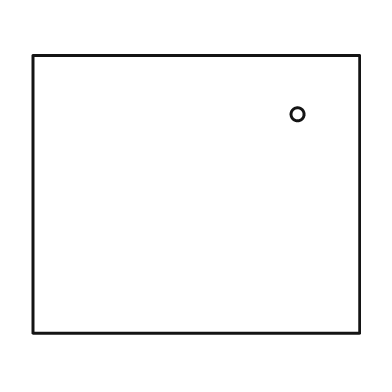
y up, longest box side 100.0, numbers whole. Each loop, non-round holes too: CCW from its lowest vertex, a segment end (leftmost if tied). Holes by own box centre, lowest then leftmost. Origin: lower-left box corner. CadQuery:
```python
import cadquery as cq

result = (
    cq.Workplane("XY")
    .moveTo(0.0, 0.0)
    .lineTo(100.0, 0.0)
    .lineTo(100.0, 85.0)
    .lineTo(0.0, 85.0)
    .close()
    .moveTo(81.0, 67.0)
    .circle(2.0)
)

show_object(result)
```